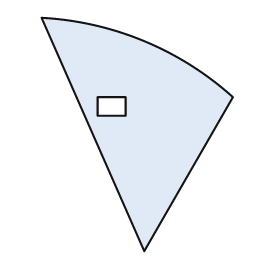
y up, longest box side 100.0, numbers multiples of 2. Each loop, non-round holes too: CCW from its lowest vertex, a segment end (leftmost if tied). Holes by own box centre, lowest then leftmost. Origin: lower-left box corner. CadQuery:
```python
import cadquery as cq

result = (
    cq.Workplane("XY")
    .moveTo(44.0, 0.0)
    .lineTo(82.0, 66.0)
    .threePointArc((44.0, 90.0), (0.0, 100.0))
    .close()
    .moveTo(24.0, 58.0)
    .lineTo(36.0, 58.0)
    .lineTo(36.0, 66.0)
    .lineTo(24.0, 66.0)
    .close()
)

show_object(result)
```